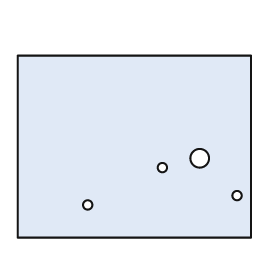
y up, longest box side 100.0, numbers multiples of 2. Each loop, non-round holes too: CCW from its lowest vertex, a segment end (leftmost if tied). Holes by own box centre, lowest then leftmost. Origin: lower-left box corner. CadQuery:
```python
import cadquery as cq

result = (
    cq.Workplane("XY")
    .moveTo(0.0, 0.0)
    .lineTo(100.0, 0.0)
    .lineTo(100.0, 78.0)
    .lineTo(0.0, 78.0)
    .close()
    .moveTo(30.0, 14.0)
    .circle(2.0)
    .moveTo(94.0, 18.0)
    .circle(2.0)
    .moveTo(62.0, 30.0)
    .circle(2.0)
    .moveTo(78.0, 34.0)
    .circle(4.0)
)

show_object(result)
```